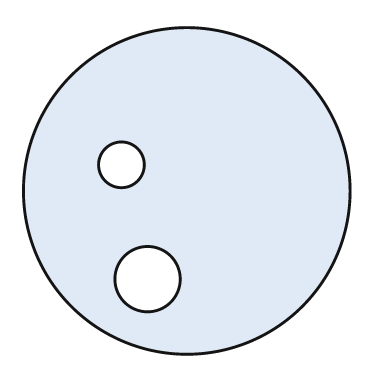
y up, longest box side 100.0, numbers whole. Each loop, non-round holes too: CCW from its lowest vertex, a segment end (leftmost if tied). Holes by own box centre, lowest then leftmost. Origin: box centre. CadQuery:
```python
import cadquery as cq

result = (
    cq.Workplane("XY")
    .moveTo(0.0, 0.0)
    .circle(50.0)
    .moveTo(-12.0, -27.0)
    .circle(10.0)
    .moveTo(-20.0, 8.0)
    .circle(7.0)
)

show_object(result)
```